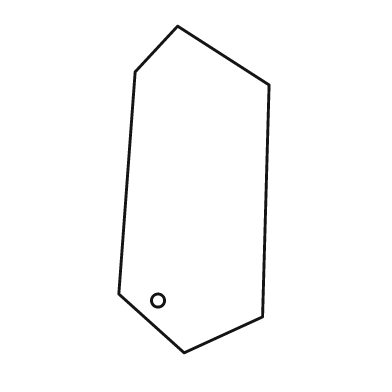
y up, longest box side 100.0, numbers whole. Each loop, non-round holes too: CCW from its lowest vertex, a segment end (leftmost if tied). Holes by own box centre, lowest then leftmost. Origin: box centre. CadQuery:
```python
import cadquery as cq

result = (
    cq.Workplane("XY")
    .moveTo(-3.0, -50.0)
    .lineTo(21.0, -39.0)
    .lineTo(23.0, 32.0)
    .lineTo(-5.0, 50.0)
    .lineTo(-18.0, 36.0)
    .lineTo(-23.0, -32.0)
    .close()
    .moveTo(-11.0, -34.0)
    .circle(2.0)
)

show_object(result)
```